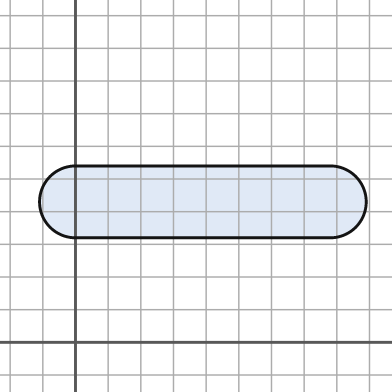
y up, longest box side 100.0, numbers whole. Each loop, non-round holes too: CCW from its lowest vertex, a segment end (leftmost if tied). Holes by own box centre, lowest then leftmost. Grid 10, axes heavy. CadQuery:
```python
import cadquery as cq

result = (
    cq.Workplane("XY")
    .moveTo(0.0, 32.0)
    .lineTo(78.0, 32.0)
    .threePointArc((89.0, 43.0), (78.0, 54.0))
    .lineTo(0.0, 54.0)
    .threePointArc((-11.0, 43.0), (0.0, 32.0))
    .close()
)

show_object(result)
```